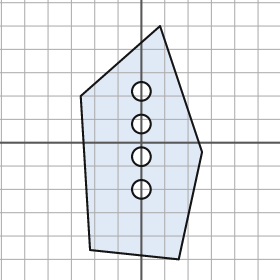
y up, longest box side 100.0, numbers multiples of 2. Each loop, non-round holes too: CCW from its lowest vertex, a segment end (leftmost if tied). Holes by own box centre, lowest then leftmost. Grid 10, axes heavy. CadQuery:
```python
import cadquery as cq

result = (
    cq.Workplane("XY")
    .moveTo(16.0, -50.0)
    .lineTo(26.0, -4.0)
    .lineTo(8.0, 50.0)
    .lineTo(-26.0, 20.0)
    .lineTo(-22.0, -46.0)
    .close()
    .moveTo(0.0, -20.0)
    .circle(4.0)
    .moveTo(0.0, -6.0)
    .circle(4.0)
    .moveTo(0.0, 8.0)
    .circle(4.0)
    .moveTo(0.0, 22.0)
    .circle(4.0)
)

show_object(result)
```